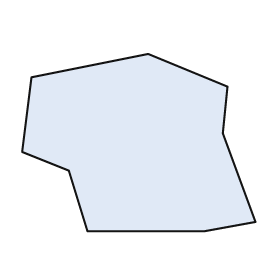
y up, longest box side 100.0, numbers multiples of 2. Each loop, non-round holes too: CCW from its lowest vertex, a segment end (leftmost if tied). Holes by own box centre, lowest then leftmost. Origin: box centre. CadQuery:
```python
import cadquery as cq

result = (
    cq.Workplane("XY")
    .moveTo(-22.0, -38.0)
    .lineTo(28.0, -38.0)
    .lineTo(50.0, -34.0)
    .lineTo(36.0, 4.0)
    .lineTo(38.0, 24.0)
    .lineTo(4.0, 38.0)
    .lineTo(-46.0, 28.0)
    .lineTo(-50.0, -4.0)
    .lineTo(-30.0, -12.0)
    .close()
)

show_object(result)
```